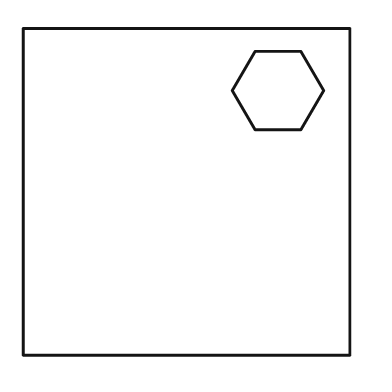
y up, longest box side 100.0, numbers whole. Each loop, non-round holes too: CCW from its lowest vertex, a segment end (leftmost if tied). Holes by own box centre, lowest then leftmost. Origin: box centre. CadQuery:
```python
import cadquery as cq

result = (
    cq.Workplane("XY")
    .moveTo(-50.0, -50.0)
    .lineTo(50.0, -50.0)
    .lineTo(50.0, 50.0)
    .lineTo(-50.0, 50.0)
    .close()
    .moveTo(21.0, 19.0)
    .lineTo(35.0, 19.0)
    .lineTo(42.0, 31.0)
    .lineTo(35.0, 43.0)
    .lineTo(21.0, 43.0)
    .lineTo(14.0, 31.0)
    .close()
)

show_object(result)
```